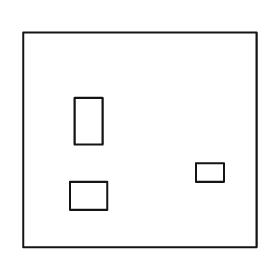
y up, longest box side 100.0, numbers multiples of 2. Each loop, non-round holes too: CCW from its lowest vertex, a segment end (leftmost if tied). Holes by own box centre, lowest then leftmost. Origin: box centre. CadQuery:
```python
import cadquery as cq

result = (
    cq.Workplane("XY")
    .moveTo(-50.0, -46.0)
    .lineTo(50.0, -46.0)
    .lineTo(50.0, 46.0)
    .lineTo(-50.0, 46.0)
    .close()
    .moveTo(-30.0, -30.0)
    .lineTo(-14.0, -30.0)
    .lineTo(-14.0, -18.0)
    .lineTo(-30.0, -18.0)
    .close()
    .moveTo(24.0, -18.0)
    .lineTo(36.0, -18.0)
    .lineTo(36.0, -10.0)
    .lineTo(24.0, -10.0)
    .close()
    .moveTo(-28.0, -2.0)
    .lineTo(-16.0, -2.0)
    .lineTo(-16.0, 18.0)
    .lineTo(-28.0, 18.0)
    .close()
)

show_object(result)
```